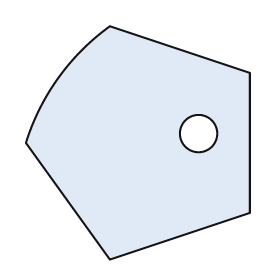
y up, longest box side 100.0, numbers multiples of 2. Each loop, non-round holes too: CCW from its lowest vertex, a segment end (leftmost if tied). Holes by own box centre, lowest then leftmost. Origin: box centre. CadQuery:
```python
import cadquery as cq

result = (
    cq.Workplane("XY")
    .moveTo(-12.0, -50.0)
    .lineTo(48.0, -30.0)
    .lineTo(48.0, 30.0)
    .lineTo(-12.0, 50.0)
    .threePointArc((-34.0, 28.0), (-48.0, 0.0))
    .close()
    .moveTo(26.0, 4.0)
    .circle(8.0)
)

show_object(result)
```